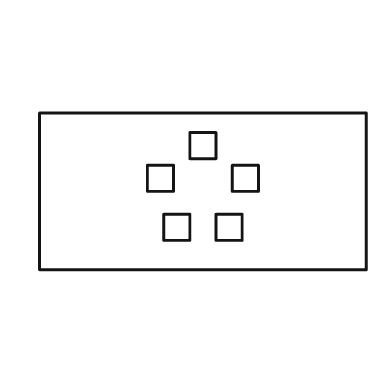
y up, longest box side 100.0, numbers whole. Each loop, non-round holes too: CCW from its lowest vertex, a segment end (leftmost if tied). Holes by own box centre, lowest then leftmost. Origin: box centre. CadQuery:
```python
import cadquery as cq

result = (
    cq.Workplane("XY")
    .moveTo(-50.0, -24.0)
    .lineTo(50.0, -24.0)
    .lineTo(50.0, 24.0)
    .lineTo(-50.0, 24.0)
    .close()
    .moveTo(-12.0, -15.0)
    .lineTo(-4.0, -15.0)
    .lineTo(-4.0, -7.0)
    .lineTo(-12.0, -7.0)
    .close()
    .moveTo(4.0, -15.0)
    .lineTo(12.0, -15.0)
    .lineTo(12.0, -7.0)
    .lineTo(4.0, -7.0)
    .close()
    .moveTo(-17.0, 0.0)
    .lineTo(-9.0, 0.0)
    .lineTo(-9.0, 8.0)
    .lineTo(-17.0, 8.0)
    .close()
    .moveTo(9.0, 0.0)
    .lineTo(17.0, 0.0)
    .lineTo(17.0, 8.0)
    .lineTo(9.0, 8.0)
    .close()
    .moveTo(-4.0, 10.0)
    .lineTo(4.0, 10.0)
    .lineTo(4.0, 18.0)
    .lineTo(-4.0, 18.0)
    .close()
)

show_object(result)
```